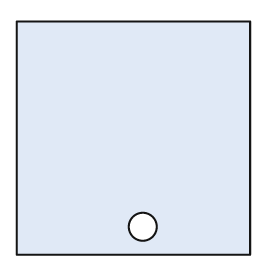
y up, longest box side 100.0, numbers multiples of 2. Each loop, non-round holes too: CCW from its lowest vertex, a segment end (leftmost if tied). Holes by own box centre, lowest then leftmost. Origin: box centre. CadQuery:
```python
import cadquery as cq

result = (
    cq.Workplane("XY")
    .moveTo(-50.0, -50.0)
    .lineTo(50.0, -50.0)
    .lineTo(50.0, 50.0)
    .lineTo(-50.0, 50.0)
    .close()
    .moveTo(4.0, -38.0)
    .circle(6.0)
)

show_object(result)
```